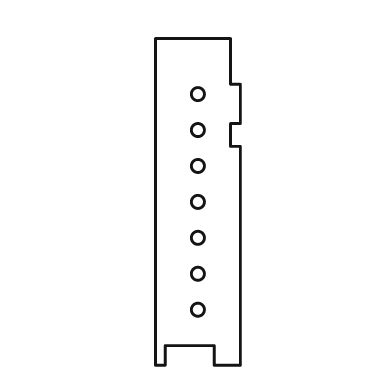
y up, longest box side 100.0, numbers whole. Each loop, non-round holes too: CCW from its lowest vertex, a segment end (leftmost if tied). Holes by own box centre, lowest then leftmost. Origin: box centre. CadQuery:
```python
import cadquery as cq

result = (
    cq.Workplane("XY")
    .moveTo(-13.0, -50.0)
    .lineTo(-10.0, -50.0)
    .lineTo(-10.0, -44.0)
    .lineTo(5.0, -44.0)
    .lineTo(5.0, -50.0)
    .lineTo(13.0, -50.0)
    .lineTo(13.0, 17.0)
    .lineTo(10.0, 17.0)
    .lineTo(10.0, 24.0)
    .lineTo(13.0, 24.0)
    .lineTo(13.0, 36.0)
    .lineTo(10.0, 36.0)
    .lineTo(10.0, 50.0)
    .lineTo(-13.0, 50.0)
    .close()
    .moveTo(0.0, -33.0)
    .circle(2.0)
    .moveTo(0.0, -22.0)
    .circle(2.0)
    .moveTo(0.0, -11.0)
    .circle(2.0)
    .moveTo(0.0, 0.0)
    .circle(2.0)
    .moveTo(0.0, 11.0)
    .circle(2.0)
    .moveTo(0.0, 22.0)
    .circle(2.0)
    .moveTo(0.0, 33.0)
    .circle(2.0)
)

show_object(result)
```